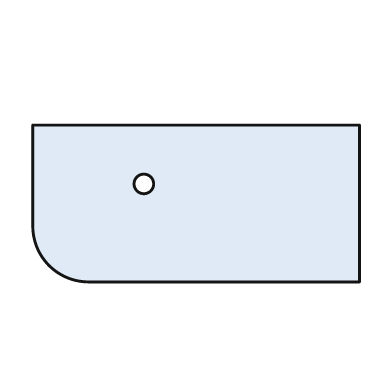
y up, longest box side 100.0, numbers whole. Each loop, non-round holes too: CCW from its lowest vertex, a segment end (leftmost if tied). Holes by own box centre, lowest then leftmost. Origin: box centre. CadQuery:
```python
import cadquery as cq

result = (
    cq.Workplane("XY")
    .moveTo(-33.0, -24.0)
    .lineTo(50.0, -24.0)
    .lineTo(50.0, 24.0)
    .lineTo(-50.0, 24.0)
    .lineTo(-50.0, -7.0)
    .threePointArc((-45.0, -19.0), (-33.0, -24.0))
    .close()
    .moveTo(-16.0, 6.0)
    .circle(3.0)
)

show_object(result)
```